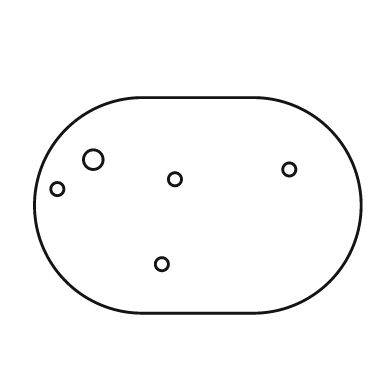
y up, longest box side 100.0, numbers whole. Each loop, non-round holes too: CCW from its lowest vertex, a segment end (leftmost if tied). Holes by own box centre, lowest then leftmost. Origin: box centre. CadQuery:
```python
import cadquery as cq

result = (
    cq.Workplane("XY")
    .moveTo(-17.0, -33.0)
    .lineTo(17.0, -33.0)
    .threePointArc((50.0, 0.0), (17.0, 33.0))
    .lineTo(-17.0, 33.0)
    .threePointArc((-50.0, 0.0), (-17.0, -33.0))
    .close()
    .moveTo(-11.0, -18.0)
    .circle(2.0)
    .moveTo(-43.0, 5.0)
    .circle(2.0)
    .moveTo(-7.0, 8.0)
    .circle(2.0)
    .moveTo(28.0, 11.0)
    .circle(2.0)
    .moveTo(-32.0, 14.0)
    .circle(3.0)
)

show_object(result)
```